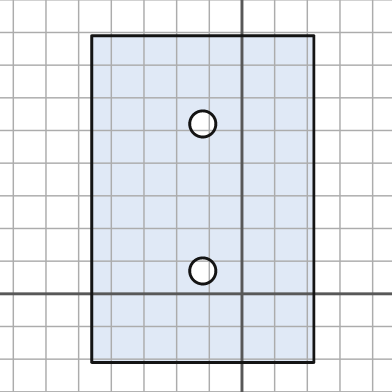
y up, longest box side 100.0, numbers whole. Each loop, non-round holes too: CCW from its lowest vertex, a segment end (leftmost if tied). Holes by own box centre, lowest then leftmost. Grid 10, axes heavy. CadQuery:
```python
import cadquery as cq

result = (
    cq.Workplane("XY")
    .moveTo(-46.0, -21.0)
    .lineTo(22.0, -21.0)
    .lineTo(22.0, 79.0)
    .lineTo(-46.0, 79.0)
    .close()
    .moveTo(-12.0, 7.0)
    .circle(4.0)
    .moveTo(-12.0, 52.0)
    .circle(4.0)
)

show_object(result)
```